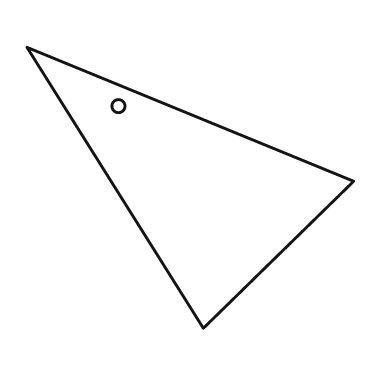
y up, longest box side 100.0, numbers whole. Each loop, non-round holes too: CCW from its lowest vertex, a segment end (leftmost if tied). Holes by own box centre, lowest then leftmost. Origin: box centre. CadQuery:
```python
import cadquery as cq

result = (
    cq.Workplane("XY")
    .moveTo(4.0, -43.0)
    .lineTo(50.0, 2.0)
    .lineTo(-50.0, 43.0)
    .close()
    .moveTo(-22.0, 25.0)
    .circle(2.0)
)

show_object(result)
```